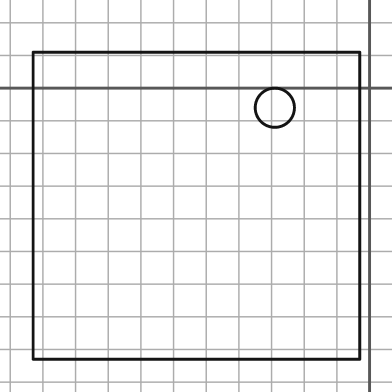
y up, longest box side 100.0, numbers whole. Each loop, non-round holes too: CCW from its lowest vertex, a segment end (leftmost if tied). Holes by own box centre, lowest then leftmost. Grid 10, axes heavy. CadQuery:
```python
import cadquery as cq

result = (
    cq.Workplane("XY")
    .moveTo(-103.0, -83.0)
    .lineTo(-3.0, -83.0)
    .lineTo(-3.0, 11.0)
    .lineTo(-103.0, 11.0)
    .close()
    .moveTo(-29.0, -6.0)
    .circle(6.0)
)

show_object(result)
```